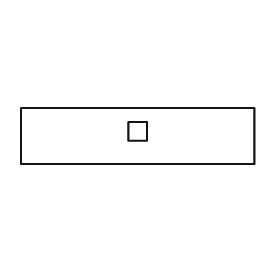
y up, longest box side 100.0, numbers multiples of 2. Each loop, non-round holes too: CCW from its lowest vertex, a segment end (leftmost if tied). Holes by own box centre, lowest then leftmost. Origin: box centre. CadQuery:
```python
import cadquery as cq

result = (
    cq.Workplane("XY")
    .moveTo(-50.0, -12.0)
    .lineTo(50.0, -12.0)
    .lineTo(50.0, 12.0)
    .lineTo(-50.0, 12.0)
    .close()
    .moveTo(-4.0, -2.0)
    .lineTo(4.0, -2.0)
    .lineTo(4.0, 6.0)
    .lineTo(-4.0, 6.0)
    .close()
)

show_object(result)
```